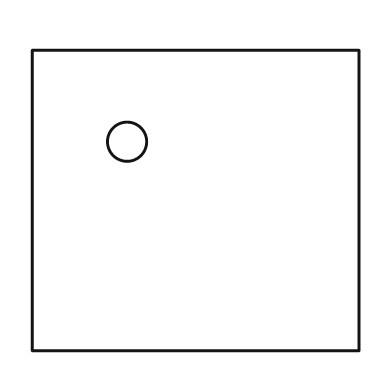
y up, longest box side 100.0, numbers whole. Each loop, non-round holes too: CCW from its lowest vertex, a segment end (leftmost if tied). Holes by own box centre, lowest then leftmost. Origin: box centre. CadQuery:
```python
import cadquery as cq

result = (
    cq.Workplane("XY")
    .moveTo(-50.0, -46.0)
    .lineTo(50.0, -46.0)
    .lineTo(50.0, 46.0)
    .lineTo(-50.0, 46.0)
    .close()
    .moveTo(-21.0, 18.0)
    .circle(6.0)
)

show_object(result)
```